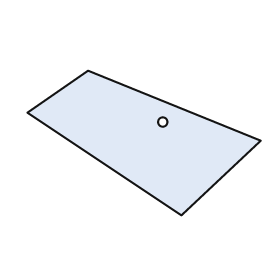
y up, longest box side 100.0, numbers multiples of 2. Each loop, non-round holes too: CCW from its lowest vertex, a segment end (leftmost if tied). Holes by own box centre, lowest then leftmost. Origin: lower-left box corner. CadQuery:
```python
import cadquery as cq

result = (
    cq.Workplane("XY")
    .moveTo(66.0, 0.0)
    .lineTo(100.0, 32.0)
    .lineTo(26.0, 62.0)
    .lineTo(0.0, 44.0)
    .close()
    .moveTo(58.0, 40.0)
    .circle(2.0)
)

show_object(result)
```